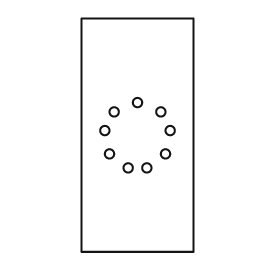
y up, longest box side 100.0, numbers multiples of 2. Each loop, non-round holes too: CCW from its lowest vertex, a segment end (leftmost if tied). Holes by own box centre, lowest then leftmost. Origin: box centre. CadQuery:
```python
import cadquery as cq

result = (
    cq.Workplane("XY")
    .moveTo(-24.0, -50.0)
    .lineTo(24.0, -50.0)
    .lineTo(24.0, 50.0)
    .lineTo(-24.0, 50.0)
    .close()
    .moveTo(-4.0, -14.0)
    .circle(2.0)
    .moveTo(4.0, -14.0)
    .circle(2.0)
    .moveTo(-12.0, -8.0)
    .circle(2.0)
    .moveTo(12.0, -8.0)
    .circle(2.0)
    .moveTo(-14.0, 2.0)
    .circle(2.0)
    .moveTo(14.0, 2.0)
    .circle(2.0)
    .moveTo(-10.0, 10.0)
    .circle(2.0)
    .moveTo(10.0, 10.0)
    .circle(2.0)
    .moveTo(0.0, 14.0)
    .circle(2.0)
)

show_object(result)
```